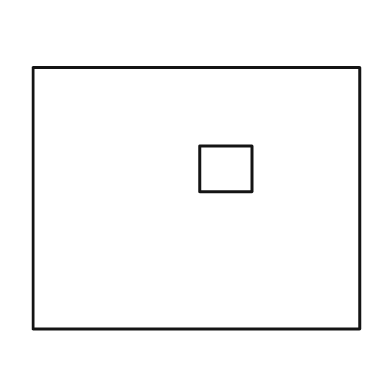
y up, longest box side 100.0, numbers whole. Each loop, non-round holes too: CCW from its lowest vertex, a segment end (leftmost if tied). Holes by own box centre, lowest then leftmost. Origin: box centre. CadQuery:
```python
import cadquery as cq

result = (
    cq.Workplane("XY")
    .moveTo(-50.0, -40.0)
    .lineTo(50.0, -40.0)
    .lineTo(50.0, 40.0)
    .lineTo(-50.0, 40.0)
    .close()
    .moveTo(1.0, 2.0)
    .lineTo(17.0, 2.0)
    .lineTo(17.0, 16.0)
    .lineTo(1.0, 16.0)
    .close()
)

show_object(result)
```